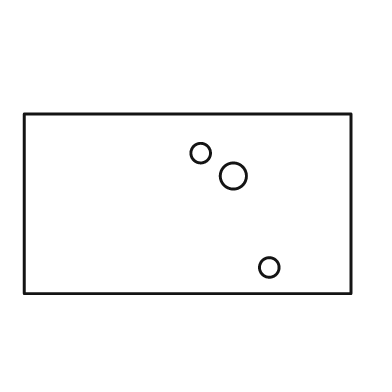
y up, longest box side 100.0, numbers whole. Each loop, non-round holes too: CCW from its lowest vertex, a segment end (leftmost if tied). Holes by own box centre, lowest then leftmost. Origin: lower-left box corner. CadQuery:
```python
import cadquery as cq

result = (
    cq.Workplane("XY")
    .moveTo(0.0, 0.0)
    .lineTo(100.0, 0.0)
    .lineTo(100.0, 55.0)
    .lineTo(0.0, 55.0)
    .close()
    .moveTo(75.0, 8.0)
    .circle(3.0)
    .moveTo(64.0, 36.0)
    .circle(4.0)
    .moveTo(54.0, 43.0)
    .circle(3.0)
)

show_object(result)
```